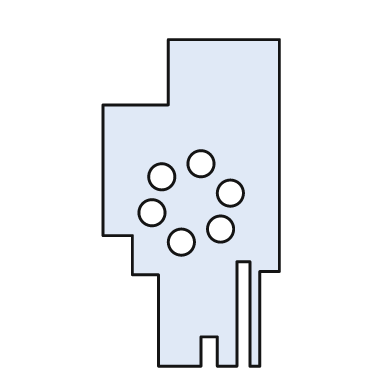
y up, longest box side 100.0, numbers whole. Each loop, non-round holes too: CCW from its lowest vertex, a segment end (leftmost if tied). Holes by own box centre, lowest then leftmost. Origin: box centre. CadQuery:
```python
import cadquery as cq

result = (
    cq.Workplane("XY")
    .moveTo(-10.0, -50.0)
    .lineTo(3.0, -50.0)
    .lineTo(3.0, -41.0)
    .lineTo(8.0, -41.0)
    .lineTo(8.0, -50.0)
    .lineTo(14.0, -50.0)
    .lineTo(14.0, -18.0)
    .lineTo(18.0, -18.0)
    .lineTo(18.0, -50.0)
    .lineTo(21.0, -50.0)
    .lineTo(21.0, -21.0)
    .lineTo(27.0, -21.0)
    .lineTo(27.0, 50.0)
    .lineTo(-7.0, 50.0)
    .lineTo(-7.0, 30.0)
    .lineTo(-27.0, 30.0)
    .lineTo(-27.0, -10.0)
    .lineTo(-18.0, -10.0)
    .lineTo(-18.0, -22.0)
    .lineTo(-10.0, -22.0)
    .close()
    .moveTo(-3.0, -12.0)
    .circle(4.0)
    .moveTo(9.0, -8.0)
    .circle(4.0)
    .moveTo(-12.0, -3.0)
    .circle(4.0)
    .moveTo(12.0, 3.0)
    .circle(4.0)
    .moveTo(-9.0, 8.0)
    .circle(4.0)
    .moveTo(3.0, 12.0)
    .circle(4.0)
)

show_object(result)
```